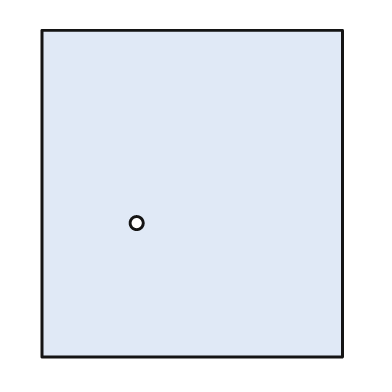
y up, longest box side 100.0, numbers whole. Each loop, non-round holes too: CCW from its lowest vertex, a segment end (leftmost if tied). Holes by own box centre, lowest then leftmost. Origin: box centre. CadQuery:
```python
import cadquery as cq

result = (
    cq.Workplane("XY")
    .moveTo(-46.0, -50.0)
    .lineTo(46.0, -50.0)
    .lineTo(46.0, 50.0)
    .lineTo(-46.0, 50.0)
    .close()
    .moveTo(-17.0, -9.0)
    .circle(2.0)
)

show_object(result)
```